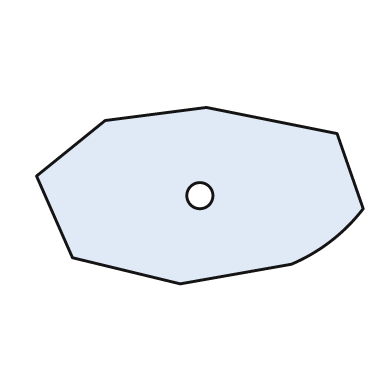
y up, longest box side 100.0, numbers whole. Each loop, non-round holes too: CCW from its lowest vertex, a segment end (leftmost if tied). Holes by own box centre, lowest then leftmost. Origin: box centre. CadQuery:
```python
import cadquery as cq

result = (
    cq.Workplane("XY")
    .moveTo(-6.0, -27.0)
    .lineTo(28.0, -21.0)
    .threePointArc((40.0, -14.0), (50.0, -4.0))
    .lineTo(42.0, 19.0)
    .lineTo(2.0, 27.0)
    .lineTo(-29.0, 23.0)
    .lineTo(-50.0, 6.0)
    .lineTo(-39.0, -19.0)
    .close()
    .moveTo(0.0, 0.0)
    .circle(4.0)
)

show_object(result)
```